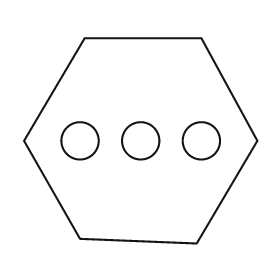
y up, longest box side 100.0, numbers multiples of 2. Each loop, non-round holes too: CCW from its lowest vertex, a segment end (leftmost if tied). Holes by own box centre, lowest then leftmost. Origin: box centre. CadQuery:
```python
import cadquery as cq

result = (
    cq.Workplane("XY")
    .moveTo(24.0, -44.0)
    .lineTo(50.0, 0.0)
    .lineTo(26.0, 44.0)
    .lineTo(-24.0, 44.0)
    .lineTo(-50.0, 0.0)
    .lineTo(-26.0, -42.0)
    .close()
    .moveTo(-26.0, 0.0)
    .circle(8.0)
    .moveTo(0.0, 0.0)
    .circle(8.0)
    .moveTo(26.0, 0.0)
    .circle(8.0)
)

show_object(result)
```